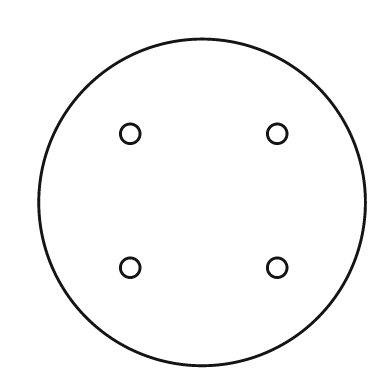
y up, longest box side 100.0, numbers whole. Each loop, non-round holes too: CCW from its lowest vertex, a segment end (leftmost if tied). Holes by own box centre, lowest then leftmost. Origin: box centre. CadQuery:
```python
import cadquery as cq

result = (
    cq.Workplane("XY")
    .moveTo(0.0, 0.0)
    .circle(50.0)
    .moveTo(-22.0, -20.0)
    .circle(3.0)
    .moveTo(23.0, -20.0)
    .circle(3.0)
    .moveTo(-22.0, 21.0)
    .circle(3.0)
    .moveTo(23.0, 21.0)
    .circle(3.0)
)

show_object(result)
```